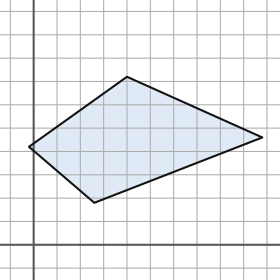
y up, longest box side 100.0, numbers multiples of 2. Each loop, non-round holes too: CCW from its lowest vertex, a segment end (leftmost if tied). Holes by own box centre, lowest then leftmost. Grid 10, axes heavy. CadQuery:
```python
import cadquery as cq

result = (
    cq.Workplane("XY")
    .moveTo(26.0, 18.0)
    .lineTo(98.0, 46.0)
    .lineTo(40.0, 72.0)
    .lineTo(-2.0, 42.0)
    .close()
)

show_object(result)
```